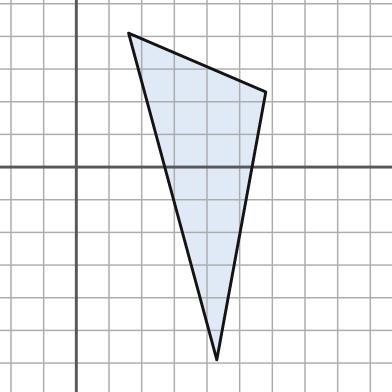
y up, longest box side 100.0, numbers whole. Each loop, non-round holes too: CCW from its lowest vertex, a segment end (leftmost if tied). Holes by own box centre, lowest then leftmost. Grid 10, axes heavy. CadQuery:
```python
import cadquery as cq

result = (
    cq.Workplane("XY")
    .moveTo(43.0, -59.0)
    .lineTo(58.0, 23.0)
    .lineTo(16.0, 41.0)
    .close()
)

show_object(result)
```